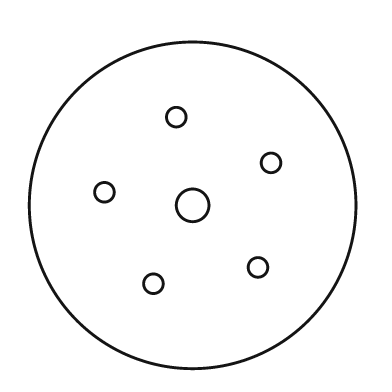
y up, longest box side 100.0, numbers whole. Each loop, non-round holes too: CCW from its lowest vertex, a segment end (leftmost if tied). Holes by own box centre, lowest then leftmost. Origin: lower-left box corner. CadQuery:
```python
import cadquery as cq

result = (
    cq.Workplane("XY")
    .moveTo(50.0, 50.0)
    .circle(50.0)
    .moveTo(38.0, 26.0)
    .circle(3.0)
    .moveTo(70.0, 31.0)
    .circle(3.0)
    .moveTo(50.0, 50.0)
    .circle(5.0)
    .moveTo(23.0, 54.0)
    .circle(3.0)
    .moveTo(74.0, 63.0)
    .circle(3.0)
    .moveTo(45.0, 77.0)
    .circle(3.0)
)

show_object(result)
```